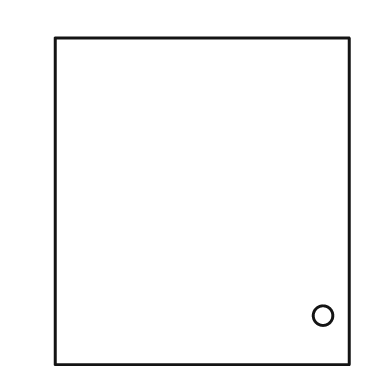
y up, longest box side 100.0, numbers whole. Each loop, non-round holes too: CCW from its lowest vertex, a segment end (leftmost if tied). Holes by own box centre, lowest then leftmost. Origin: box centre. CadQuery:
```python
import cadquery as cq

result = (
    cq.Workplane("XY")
    .moveTo(-45.0, -50.0)
    .lineTo(45.0, -50.0)
    .lineTo(45.0, 50.0)
    .lineTo(-45.0, 50.0)
    .close()
    .moveTo(37.0, -35.0)
    .circle(3.0)
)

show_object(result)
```